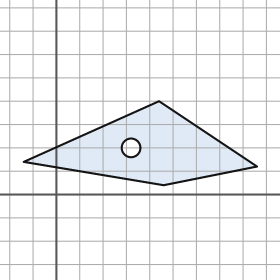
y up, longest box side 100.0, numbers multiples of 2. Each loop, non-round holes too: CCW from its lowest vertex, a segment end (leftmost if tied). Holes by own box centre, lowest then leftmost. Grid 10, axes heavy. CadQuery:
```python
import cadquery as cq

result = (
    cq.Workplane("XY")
    .moveTo(46.0, 4.0)
    .lineTo(86.0, 12.0)
    .lineTo(44.0, 40.0)
    .lineTo(-14.0, 14.0)
    .close()
    .moveTo(32.0, 20.0)
    .circle(4.0)
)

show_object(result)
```